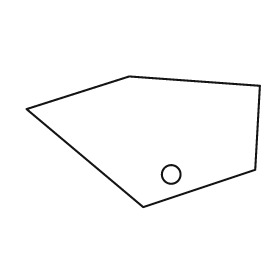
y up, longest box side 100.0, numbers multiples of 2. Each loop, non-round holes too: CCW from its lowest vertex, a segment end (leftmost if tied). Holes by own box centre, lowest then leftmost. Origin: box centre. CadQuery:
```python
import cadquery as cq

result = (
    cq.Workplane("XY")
    .moveTo(0.0, -28.0)
    .lineTo(48.0, -12.0)
    .lineTo(50.0, 24.0)
    .lineTo(-6.0, 28.0)
    .lineTo(-50.0, 14.0)
    .close()
    .moveTo(12.0, -14.0)
    .circle(4.0)
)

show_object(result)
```